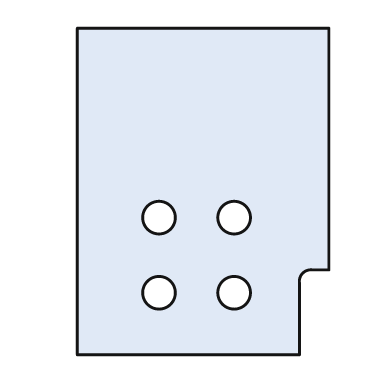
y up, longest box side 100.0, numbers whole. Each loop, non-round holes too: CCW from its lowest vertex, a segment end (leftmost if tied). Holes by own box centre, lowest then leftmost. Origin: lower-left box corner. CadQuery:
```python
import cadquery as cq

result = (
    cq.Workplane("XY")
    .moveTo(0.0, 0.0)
    .lineTo(68.0, 0.0)
    .lineTo(68.0, 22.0)
    .threePointArc((69.0, 25.0), (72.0, 26.0))
    .lineTo(77.0, 26.0)
    .lineTo(77.0, 100.0)
    .lineTo(0.0, 100.0)
    .close()
    .moveTo(25.0, 19.0)
    .circle(5.0)
    .moveTo(48.0, 19.0)
    .circle(5.0)
    .moveTo(25.0, 42.0)
    .circle(5.0)
    .moveTo(48.0, 42.0)
    .circle(5.0)
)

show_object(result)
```